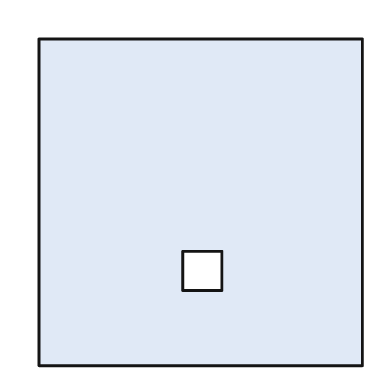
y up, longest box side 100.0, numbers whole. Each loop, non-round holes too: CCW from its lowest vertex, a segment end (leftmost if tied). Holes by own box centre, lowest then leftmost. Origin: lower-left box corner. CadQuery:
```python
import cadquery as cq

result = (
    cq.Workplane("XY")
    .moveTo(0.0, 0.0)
    .lineTo(99.0, 0.0)
    .lineTo(99.0, 100.0)
    .lineTo(0.0, 100.0)
    .close()
    .moveTo(44.0, 23.0)
    .lineTo(56.0, 23.0)
    .lineTo(56.0, 35.0)
    .lineTo(44.0, 35.0)
    .close()
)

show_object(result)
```